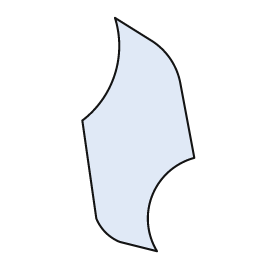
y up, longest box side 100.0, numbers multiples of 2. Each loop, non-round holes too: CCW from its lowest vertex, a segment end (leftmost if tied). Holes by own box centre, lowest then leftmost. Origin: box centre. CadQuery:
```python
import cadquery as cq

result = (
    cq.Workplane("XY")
    .moveTo(8.0, -50.0)
    .threePointArc((6.0, -26.0), (24.0, -10.0))
    .lineTo(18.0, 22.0)
    .threePointArc((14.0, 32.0), (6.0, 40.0))
    .lineTo(-10.0, 50.0)
    .threePointArc((-10.0, 26.0), (-24.0, 6.0))
    .lineTo(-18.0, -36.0)
    .threePointArc((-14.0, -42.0), (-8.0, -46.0))
    .close()
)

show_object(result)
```